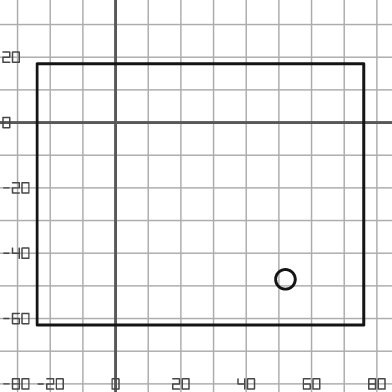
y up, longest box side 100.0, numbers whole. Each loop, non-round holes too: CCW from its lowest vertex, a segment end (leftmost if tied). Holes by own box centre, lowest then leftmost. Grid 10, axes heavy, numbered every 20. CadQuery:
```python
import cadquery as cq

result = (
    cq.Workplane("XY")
    .moveTo(-24.0, -62.0)
    .lineTo(76.0, -62.0)
    .lineTo(76.0, 18.0)
    .lineTo(-24.0, 18.0)
    .close()
    .moveTo(52.0, -48.0)
    .circle(3.0)
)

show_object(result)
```